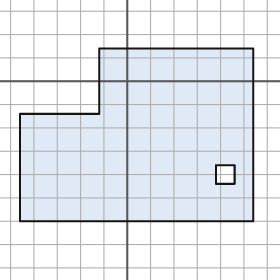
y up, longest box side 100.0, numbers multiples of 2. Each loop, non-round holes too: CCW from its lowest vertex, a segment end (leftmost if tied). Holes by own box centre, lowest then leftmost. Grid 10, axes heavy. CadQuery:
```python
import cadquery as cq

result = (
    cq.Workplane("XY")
    .moveTo(-46.0, -60.0)
    .lineTo(54.0, -60.0)
    .lineTo(54.0, 14.0)
    .lineTo(-12.0, 14.0)
    .lineTo(-12.0, -14.0)
    .lineTo(-46.0, -14.0)
    .close()
    .moveTo(38.0, -44.0)
    .lineTo(46.0, -44.0)
    .lineTo(46.0, -36.0)
    .lineTo(38.0, -36.0)
    .close()
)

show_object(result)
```